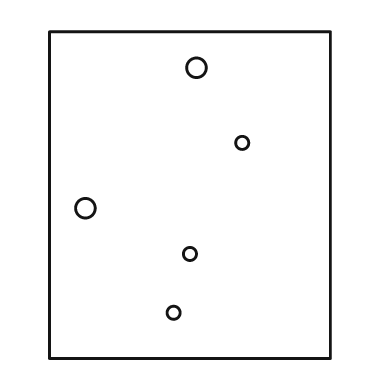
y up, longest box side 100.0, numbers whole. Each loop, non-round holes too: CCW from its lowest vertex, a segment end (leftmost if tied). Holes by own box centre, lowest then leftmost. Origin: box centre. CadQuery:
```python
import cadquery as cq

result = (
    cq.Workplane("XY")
    .moveTo(-43.0, -50.0)
    .lineTo(43.0, -50.0)
    .lineTo(43.0, 50.0)
    .lineTo(-43.0, 50.0)
    .close()
    .moveTo(-5.0, -36.0)
    .circle(2.0)
    .moveTo(0.0, -18.0)
    .circle(2.0)
    .moveTo(-32.0, -4.0)
    .circle(3.0)
    .moveTo(16.0, 16.0)
    .circle(2.0)
    .moveTo(2.0, 39.0)
    .circle(3.0)
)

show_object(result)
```